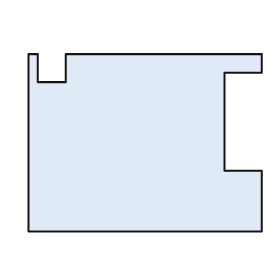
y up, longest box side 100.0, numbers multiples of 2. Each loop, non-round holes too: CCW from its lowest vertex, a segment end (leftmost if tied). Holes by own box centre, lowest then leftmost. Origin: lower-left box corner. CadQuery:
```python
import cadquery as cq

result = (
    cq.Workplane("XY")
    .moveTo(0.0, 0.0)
    .lineTo(100.0, 0.0)
    .lineTo(100.0, 26.0)
    .lineTo(84.0, 26.0)
    .lineTo(84.0, 68.0)
    .lineTo(100.0, 68.0)
    .lineTo(100.0, 76.0)
    .lineTo(16.0, 76.0)
    .lineTo(16.0, 64.0)
    .lineTo(4.0, 64.0)
    .lineTo(4.0, 76.0)
    .lineTo(0.0, 76.0)
    .close()
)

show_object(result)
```